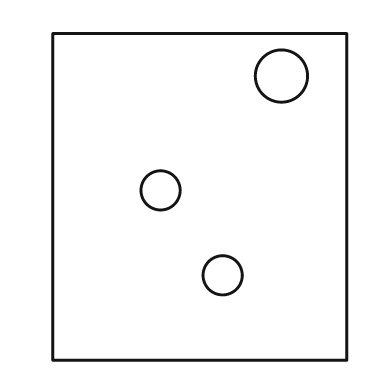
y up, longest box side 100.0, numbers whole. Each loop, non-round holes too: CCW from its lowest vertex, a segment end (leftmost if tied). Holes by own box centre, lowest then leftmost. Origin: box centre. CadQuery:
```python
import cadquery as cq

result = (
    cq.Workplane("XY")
    .moveTo(-45.0, -50.0)
    .lineTo(45.0, -50.0)
    .lineTo(45.0, 50.0)
    .lineTo(-45.0, 50.0)
    .close()
    .moveTo(7.0, -24.0)
    .circle(6.0)
    .moveTo(-12.0, 2.0)
    .circle(6.0)
    .moveTo(25.0, 37.0)
    .circle(8.0)
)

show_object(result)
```